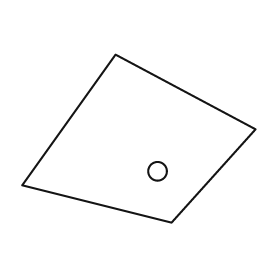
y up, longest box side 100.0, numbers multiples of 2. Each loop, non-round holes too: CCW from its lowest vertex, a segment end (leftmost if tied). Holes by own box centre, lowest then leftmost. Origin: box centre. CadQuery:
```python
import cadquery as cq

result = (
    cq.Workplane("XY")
    .moveTo(14.0, -36.0)
    .lineTo(50.0, 4.0)
    .lineTo(-10.0, 36.0)
    .lineTo(-50.0, -20.0)
    .close()
    .moveTo(8.0, -14.0)
    .circle(4.0)
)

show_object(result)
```